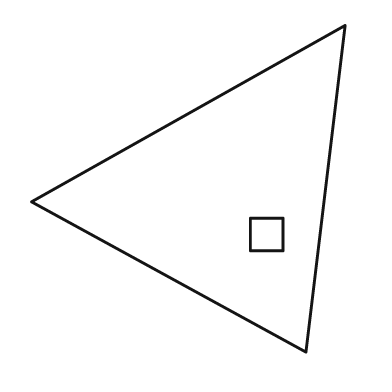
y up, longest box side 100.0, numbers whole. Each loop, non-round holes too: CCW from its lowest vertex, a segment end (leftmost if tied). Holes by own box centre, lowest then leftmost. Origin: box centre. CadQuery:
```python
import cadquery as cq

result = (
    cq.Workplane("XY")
    .moveTo(36.0, -50.0)
    .lineTo(48.0, 50.0)
    .lineTo(-48.0, -4.0)
    .close()
    .moveTo(19.0, -19.0)
    .lineTo(29.0, -19.0)
    .lineTo(29.0, -9.0)
    .lineTo(19.0, -9.0)
    .close()
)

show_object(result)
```